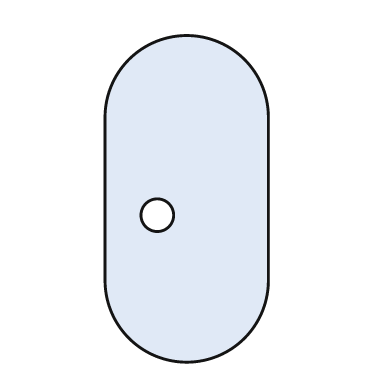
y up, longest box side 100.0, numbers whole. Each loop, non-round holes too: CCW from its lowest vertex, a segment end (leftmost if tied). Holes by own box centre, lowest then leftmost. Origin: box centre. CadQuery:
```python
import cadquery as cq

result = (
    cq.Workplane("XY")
    .moveTo(-25.0, -25.0)
    .threePointArc((0.0, -50.0), (25.0, -25.0))
    .lineTo(25.0, 25.0)
    .threePointArc((0.0, 50.0), (-25.0, 25.0))
    .close()
    .moveTo(-9.0, -5.0)
    .circle(5.0)
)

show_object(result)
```